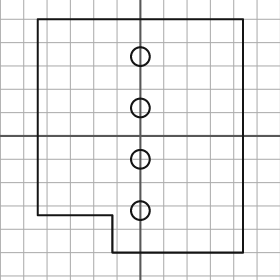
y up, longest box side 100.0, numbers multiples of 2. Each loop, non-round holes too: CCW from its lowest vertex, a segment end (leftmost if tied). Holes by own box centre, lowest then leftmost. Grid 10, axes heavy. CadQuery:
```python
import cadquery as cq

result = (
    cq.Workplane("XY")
    .moveTo(-12.0, -50.0)
    .lineTo(44.0, -50.0)
    .lineTo(44.0, 50.0)
    .lineTo(-44.0, 50.0)
    .lineTo(-44.0, -34.0)
    .lineTo(-12.0, -34.0)
    .close()
    .moveTo(0.0, -32.0)
    .circle(4.0)
    .moveTo(0.0, -10.0)
    .circle(4.0)
    .moveTo(0.0, 12.0)
    .circle(4.0)
    .moveTo(0.0, 34.0)
    .circle(4.0)
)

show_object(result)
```